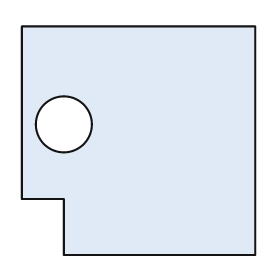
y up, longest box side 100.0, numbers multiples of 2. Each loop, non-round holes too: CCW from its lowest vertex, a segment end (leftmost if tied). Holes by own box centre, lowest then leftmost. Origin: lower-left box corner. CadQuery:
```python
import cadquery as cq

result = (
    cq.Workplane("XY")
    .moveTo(18.0, 0.0)
    .lineTo(100.0, 0.0)
    .lineTo(100.0, 98.0)
    .lineTo(0.0, 98.0)
    .lineTo(0.0, 24.0)
    .lineTo(18.0, 24.0)
    .close()
    .moveTo(18.0, 56.0)
    .circle(12.0)
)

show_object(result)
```